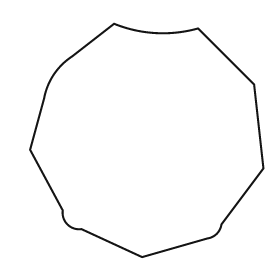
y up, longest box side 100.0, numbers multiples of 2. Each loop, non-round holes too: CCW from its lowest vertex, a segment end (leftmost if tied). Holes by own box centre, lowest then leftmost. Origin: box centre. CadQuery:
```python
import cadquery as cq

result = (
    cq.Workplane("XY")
    .moveTo(-2.0, -50.0)
    .lineTo(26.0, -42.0)
    .threePointArc((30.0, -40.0), (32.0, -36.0))
    .lineTo(50.0, -12.0)
    .lineTo(46.0, 24.0)
    .lineTo(22.0, 48.0)
    .threePointArc((4.0, 46.0), (-14.0, 50.0))
    .lineTo(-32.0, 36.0)
    .threePointArc((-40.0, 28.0), (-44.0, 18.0))
    .lineTo(-50.0, -4.0)
    .lineTo(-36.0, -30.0)
    .threePointArc((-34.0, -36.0), (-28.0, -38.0))
    .close()
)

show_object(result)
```